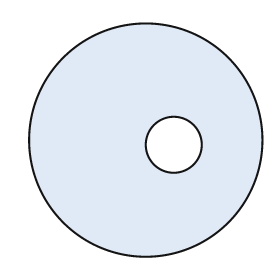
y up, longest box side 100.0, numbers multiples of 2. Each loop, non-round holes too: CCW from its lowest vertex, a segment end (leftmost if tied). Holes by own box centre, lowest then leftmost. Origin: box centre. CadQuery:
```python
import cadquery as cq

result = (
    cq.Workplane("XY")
    .moveTo(0.0, 0.0)
    .circle(50.0)
    .moveTo(12.0, -2.0)
    .circle(12.0)
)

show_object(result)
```